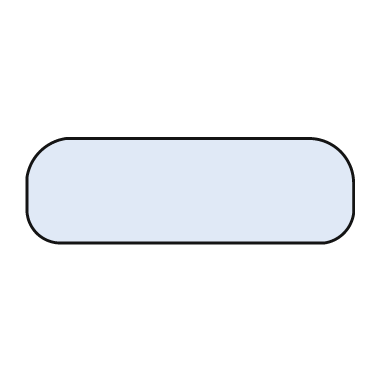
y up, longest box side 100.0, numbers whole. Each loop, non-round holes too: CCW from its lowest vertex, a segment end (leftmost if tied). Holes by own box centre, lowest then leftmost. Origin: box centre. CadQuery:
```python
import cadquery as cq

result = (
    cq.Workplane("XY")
    .moveTo(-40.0, -16.0)
    .lineTo(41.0, -16.0)
    .threePointArc((47.0, -13.0), (50.0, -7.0))
    .lineTo(50.0, 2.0)
    .threePointArc((46.0, 12.0), (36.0, 16.0))
    .lineTo(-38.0, 16.0)
    .threePointArc((-46.0, 12.0), (-50.0, 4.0))
    .lineTo(-50.0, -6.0)
    .threePointArc((-47.0, -13.0), (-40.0, -16.0))
    .close()
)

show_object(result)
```